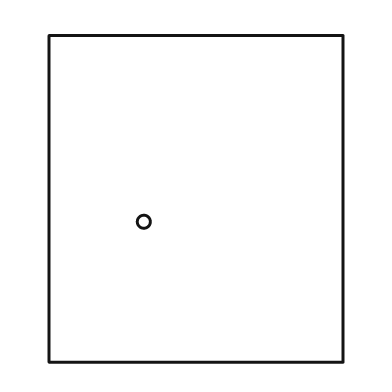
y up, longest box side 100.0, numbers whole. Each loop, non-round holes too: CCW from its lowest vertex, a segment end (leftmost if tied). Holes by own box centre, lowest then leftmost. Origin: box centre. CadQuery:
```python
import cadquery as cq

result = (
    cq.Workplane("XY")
    .moveTo(-45.0, -50.0)
    .lineTo(45.0, -50.0)
    .lineTo(45.0, 50.0)
    .lineTo(-45.0, 50.0)
    .close()
    .moveTo(-16.0, -7.0)
    .circle(2.0)
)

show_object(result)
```